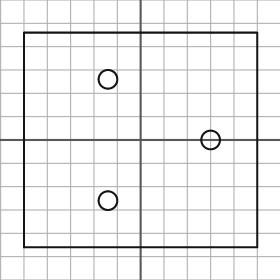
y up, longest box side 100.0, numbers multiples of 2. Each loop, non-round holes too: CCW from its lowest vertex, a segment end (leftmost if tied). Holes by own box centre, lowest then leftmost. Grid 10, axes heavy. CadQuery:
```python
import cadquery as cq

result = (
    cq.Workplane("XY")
    .moveTo(-50.0, -46.0)
    .lineTo(50.0, -46.0)
    .lineTo(50.0, 46.0)
    .lineTo(-50.0, 46.0)
    .close()
    .moveTo(-14.0, -26.0)
    .circle(4.0)
    .moveTo(30.0, 0.0)
    .circle(4.0)
    .moveTo(-14.0, 26.0)
    .circle(4.0)
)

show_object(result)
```